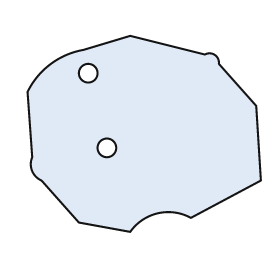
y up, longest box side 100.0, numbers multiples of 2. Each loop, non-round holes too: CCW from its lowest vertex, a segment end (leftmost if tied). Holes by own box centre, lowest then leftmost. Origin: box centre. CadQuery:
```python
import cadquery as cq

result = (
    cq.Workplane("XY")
    .moveTo(-6.0, -42.0)
    .threePointArc((6.0, -34.0), (20.0, -36.0))
    .lineTo(50.0, -20.0)
    .lineTo(48.0, 12.0)
    .lineTo(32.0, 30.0)
    .threePointArc((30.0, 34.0), (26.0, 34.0))
    .lineTo(-6.0, 42.0)
    .lineTo(-26.0, 36.0)
    .threePointArc((-40.0, 30.0), (-50.0, 18.0))
    .lineTo(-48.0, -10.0)
    .threePointArc((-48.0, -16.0), (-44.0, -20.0))
    .lineTo(-28.0, -38.0)
    .close()
    .moveTo(-16.0, -6.0)
    .circle(4.0)
    .moveTo(-24.0, 26.0)
    .circle(4.0)
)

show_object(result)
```